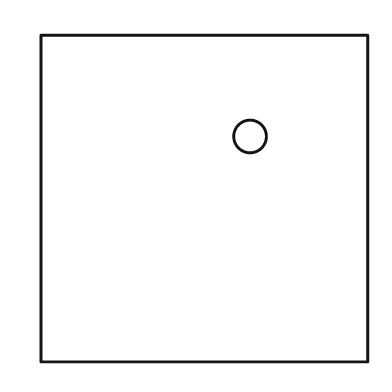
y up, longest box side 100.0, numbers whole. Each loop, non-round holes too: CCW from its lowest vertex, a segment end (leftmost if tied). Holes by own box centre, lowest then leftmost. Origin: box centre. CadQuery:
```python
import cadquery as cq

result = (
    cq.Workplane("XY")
    .moveTo(-50.0, -50.0)
    .lineTo(50.0, -50.0)
    .lineTo(50.0, 50.0)
    .lineTo(-50.0, 50.0)
    .close()
    .moveTo(14.0, 19.0)
    .circle(5.0)
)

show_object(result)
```